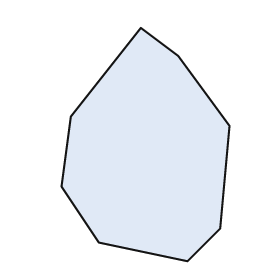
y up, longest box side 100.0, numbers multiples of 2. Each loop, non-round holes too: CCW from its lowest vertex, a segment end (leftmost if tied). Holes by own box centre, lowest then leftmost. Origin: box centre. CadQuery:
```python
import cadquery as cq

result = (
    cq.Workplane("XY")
    .moveTo(18.0, -50.0)
    .lineTo(32.0, -36.0)
    .lineTo(36.0, 8.0)
    .lineTo(14.0, 38.0)
    .lineTo(-2.0, 50.0)
    .lineTo(-32.0, 12.0)
    .lineTo(-36.0, -18.0)
    .lineTo(-20.0, -42.0)
    .close()
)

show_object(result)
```